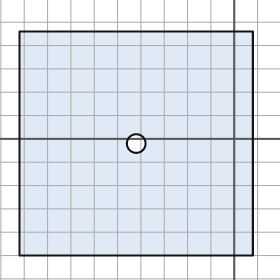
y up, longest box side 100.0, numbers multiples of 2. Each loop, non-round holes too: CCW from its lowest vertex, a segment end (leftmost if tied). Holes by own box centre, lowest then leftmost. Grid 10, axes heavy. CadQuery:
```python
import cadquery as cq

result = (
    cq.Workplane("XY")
    .moveTo(-92.0, -50.0)
    .lineTo(8.0, -50.0)
    .lineTo(8.0, 46.0)
    .lineTo(-92.0, 46.0)
    .close()
    .moveTo(-42.0, -2.0)
    .circle(4.0)
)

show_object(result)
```